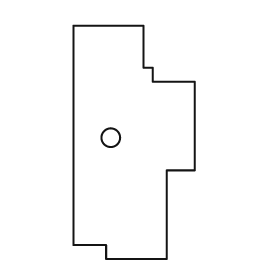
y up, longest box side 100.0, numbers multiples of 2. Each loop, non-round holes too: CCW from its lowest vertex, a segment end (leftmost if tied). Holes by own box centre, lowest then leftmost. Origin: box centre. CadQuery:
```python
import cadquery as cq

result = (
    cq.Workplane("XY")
    .moveTo(-12.0, -50.0)
    .lineTo(14.0, -50.0)
    .lineTo(14.0, -12.0)
    .lineTo(26.0, -12.0)
    .lineTo(26.0, 26.0)
    .lineTo(8.0, 26.0)
    .lineTo(8.0, 32.0)
    .lineTo(4.0, 32.0)
    .lineTo(4.0, 50.0)
    .lineTo(-26.0, 50.0)
    .lineTo(-26.0, -44.0)
    .lineTo(-12.0, -44.0)
    .close()
    .moveTo(-10.0, 2.0)
    .circle(4.0)
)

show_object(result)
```